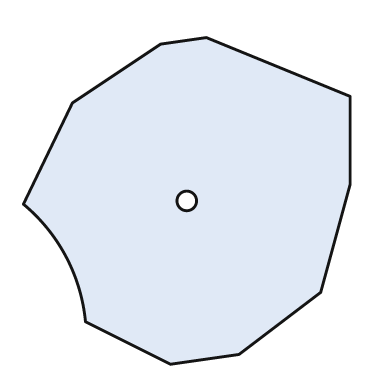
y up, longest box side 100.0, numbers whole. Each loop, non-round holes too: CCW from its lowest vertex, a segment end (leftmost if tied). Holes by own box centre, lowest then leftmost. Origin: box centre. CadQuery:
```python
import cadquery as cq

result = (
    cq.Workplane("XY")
    .moveTo(-5.0, -50.0)
    .lineTo(16.0, -47.0)
    .lineTo(41.0, -28.0)
    .lineTo(50.0, 5.0)
    .lineTo(50.0, 32.0)
    .lineTo(6.0, 50.0)
    .lineTo(-8.0, 48.0)
    .lineTo(-35.0, 30.0)
    .lineTo(-50.0, -1.0)
    .threePointArc((-37.0, -17.0), (-31.0, -37.0))
    .close()
    .moveTo(0.0, 0.0)
    .circle(3.0)
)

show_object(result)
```